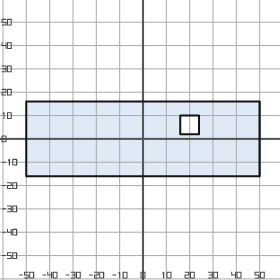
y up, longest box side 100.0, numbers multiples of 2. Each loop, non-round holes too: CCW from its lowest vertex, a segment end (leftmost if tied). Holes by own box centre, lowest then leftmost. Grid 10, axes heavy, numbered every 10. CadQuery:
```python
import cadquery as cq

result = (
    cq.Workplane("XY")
    .moveTo(-50.0, -16.0)
    .lineTo(50.0, -16.0)
    .lineTo(50.0, 16.0)
    .lineTo(-50.0, 16.0)
    .close()
    .moveTo(16.0, 2.0)
    .lineTo(24.0, 2.0)
    .lineTo(24.0, 10.0)
    .lineTo(16.0, 10.0)
    .close()
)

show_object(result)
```